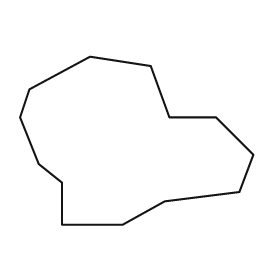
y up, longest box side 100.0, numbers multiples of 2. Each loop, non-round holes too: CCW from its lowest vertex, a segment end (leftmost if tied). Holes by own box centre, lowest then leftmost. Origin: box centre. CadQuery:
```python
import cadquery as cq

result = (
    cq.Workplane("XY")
    .moveTo(-32.0, -36.0)
    .lineTo(-6.0, -36.0)
    .lineTo(12.0, -26.0)
    .lineTo(44.0, -22.0)
    .lineTo(50.0, -6.0)
    .lineTo(34.0, 10.0)
    .lineTo(14.0, 10.0)
    .lineTo(6.0, 32.0)
    .lineTo(-20.0, 36.0)
    .lineTo(-46.0, 22.0)
    .lineTo(-50.0, 10.0)
    .lineTo(-42.0, -10.0)
    .lineTo(-32.0, -18.0)
    .close()
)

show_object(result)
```